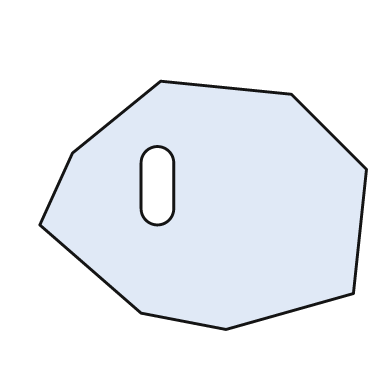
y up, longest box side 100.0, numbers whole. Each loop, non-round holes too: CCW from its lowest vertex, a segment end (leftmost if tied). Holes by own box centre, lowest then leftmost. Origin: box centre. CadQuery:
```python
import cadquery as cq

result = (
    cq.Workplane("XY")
    .moveTo(7.0, -38.0)
    .lineTo(46.0, -27.0)
    .lineTo(50.0, 11.0)
    .lineTo(27.0, 34.0)
    .lineTo(-13.0, 38.0)
    .lineTo(-40.0, 16.0)
    .lineTo(-50.0, -6.0)
    .lineTo(-19.0, -33.0)
    .close()
    .moveTo(-19.0, -1.0)
    .threePointArc((-14.0, -6.0), (-9.0, -1.0))
    .lineTo(-9.0, 13.0)
    .threePointArc((-14.0, 18.0), (-19.0, 13.0))
    .close()
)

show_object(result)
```